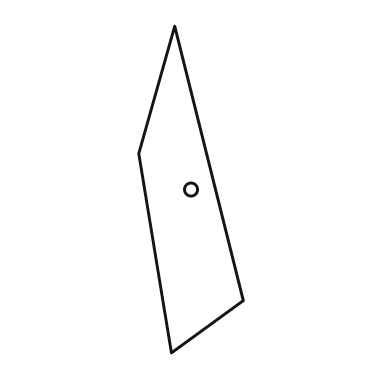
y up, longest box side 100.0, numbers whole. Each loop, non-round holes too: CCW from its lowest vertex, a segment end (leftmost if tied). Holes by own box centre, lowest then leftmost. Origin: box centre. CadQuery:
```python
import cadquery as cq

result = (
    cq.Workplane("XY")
    .moveTo(-6.0, -50.0)
    .lineTo(16.0, -34.0)
    .lineTo(-5.0, 50.0)
    .lineTo(-16.0, 11.0)
    .close()
    .moveTo(0.0, 0.0)
    .circle(2.0)
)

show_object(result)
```